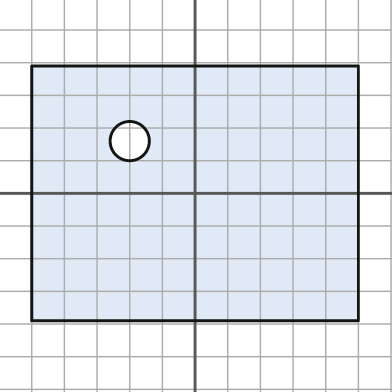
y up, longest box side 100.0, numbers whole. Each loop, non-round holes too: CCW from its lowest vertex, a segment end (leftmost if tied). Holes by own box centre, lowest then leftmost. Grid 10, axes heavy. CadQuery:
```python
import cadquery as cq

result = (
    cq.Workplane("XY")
    .moveTo(-50.0, -39.0)
    .lineTo(50.0, -39.0)
    .lineTo(50.0, 39.0)
    .lineTo(-50.0, 39.0)
    .close()
    .moveTo(-20.0, 16.0)
    .circle(6.0)
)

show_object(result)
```